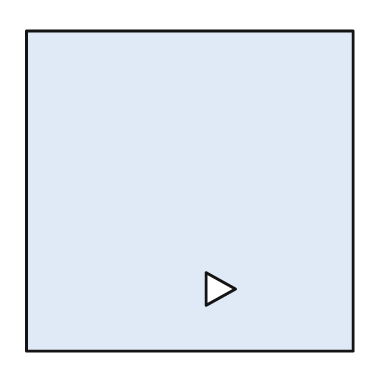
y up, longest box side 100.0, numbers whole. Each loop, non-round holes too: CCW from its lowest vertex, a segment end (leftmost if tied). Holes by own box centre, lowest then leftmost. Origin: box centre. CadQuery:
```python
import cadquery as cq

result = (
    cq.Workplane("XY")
    .moveTo(-50.0, -49.0)
    .lineTo(50.0, -49.0)
    .lineTo(50.0, 49.0)
    .lineTo(-50.0, 49.0)
    .close()
    .moveTo(5.0, -35.0)
    .lineTo(14.0, -30.0)
    .lineTo(5.0, -25.0)
    .close()
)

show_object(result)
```